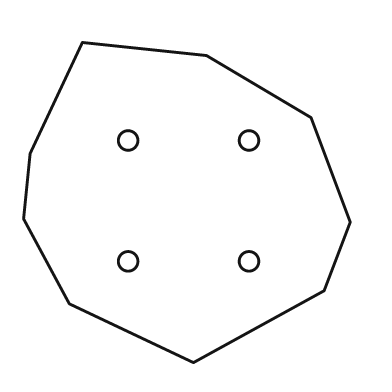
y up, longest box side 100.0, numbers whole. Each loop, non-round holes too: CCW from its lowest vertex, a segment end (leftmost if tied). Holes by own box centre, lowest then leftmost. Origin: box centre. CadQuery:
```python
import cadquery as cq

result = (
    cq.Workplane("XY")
    .moveTo(2.0, -49.0)
    .lineTo(42.0, -27.0)
    .lineTo(50.0, -6.0)
    .lineTo(38.0, 26.0)
    .lineTo(6.0, 45.0)
    .lineTo(-32.0, 49.0)
    .lineTo(-48.0, 15.0)
    .lineTo(-50.0, -5.0)
    .lineTo(-36.0, -31.0)
    .close()
    .moveTo(-18.0, -18.0)
    .circle(3.0)
    .moveTo(19.0, -18.0)
    .circle(3.0)
    .moveTo(-18.0, 19.0)
    .circle(3.0)
    .moveTo(19.0, 19.0)
    .circle(3.0)
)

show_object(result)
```